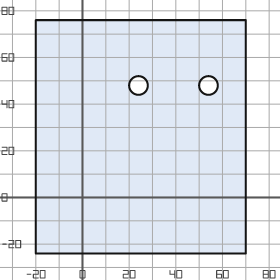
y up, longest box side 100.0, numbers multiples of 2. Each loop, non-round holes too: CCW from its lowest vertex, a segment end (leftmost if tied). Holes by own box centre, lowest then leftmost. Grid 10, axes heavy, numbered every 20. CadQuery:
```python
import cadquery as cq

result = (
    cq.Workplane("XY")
    .moveTo(-20.0, -24.0)
    .lineTo(70.0, -24.0)
    .lineTo(70.0, 76.0)
    .lineTo(-20.0, 76.0)
    .close()
    .moveTo(24.0, 48.0)
    .circle(4.0)
    .moveTo(54.0, 48.0)
    .circle(4.0)
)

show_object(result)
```